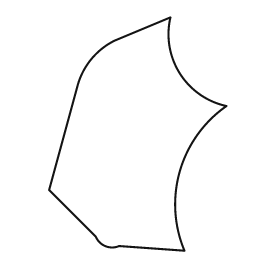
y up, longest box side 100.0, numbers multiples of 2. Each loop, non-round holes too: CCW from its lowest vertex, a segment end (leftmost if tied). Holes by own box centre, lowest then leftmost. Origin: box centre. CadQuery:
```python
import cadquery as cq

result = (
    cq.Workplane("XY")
    .moveTo(20.0, -50.0)
    .threePointArc((18.0, -16.0), (38.0, 12.0))
    .threePointArc((18.0, 26.0), (14.0, 50.0))
    .lineTo(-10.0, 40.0)
    .threePointArc((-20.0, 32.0), (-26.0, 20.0))
    .lineTo(-38.0, -24.0)
    .lineTo(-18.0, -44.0)
    .threePointArc((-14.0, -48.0), (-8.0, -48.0))
    .close()
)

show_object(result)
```